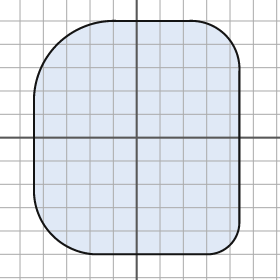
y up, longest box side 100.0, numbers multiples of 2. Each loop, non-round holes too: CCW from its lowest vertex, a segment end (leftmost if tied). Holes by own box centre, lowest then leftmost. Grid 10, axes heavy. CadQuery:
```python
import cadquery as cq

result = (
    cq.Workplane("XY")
    .moveTo(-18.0, -50.0)
    .lineTo(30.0, -50.0)
    .threePointArc((40.0, -46.0), (44.0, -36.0))
    .lineTo(44.0, 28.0)
    .threePointArc((38.0, 44.0), (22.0, 50.0))
    .lineTo(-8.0, 50.0)
    .threePointArc((-34.0, 40.0), (-44.0, 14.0))
    .lineTo(-44.0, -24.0)
    .threePointArc((-36.0, -42.0), (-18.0, -50.0))
    .close()
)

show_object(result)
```